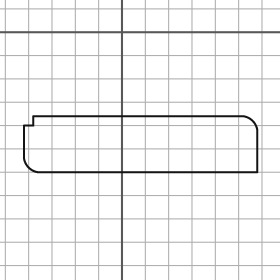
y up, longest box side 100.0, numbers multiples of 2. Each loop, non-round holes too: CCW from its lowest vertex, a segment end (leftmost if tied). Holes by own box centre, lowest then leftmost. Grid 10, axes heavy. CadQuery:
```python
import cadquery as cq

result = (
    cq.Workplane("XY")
    .moveTo(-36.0, -60.0)
    .lineTo(58.0, -60.0)
    .lineTo(58.0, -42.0)
    .threePointArc((56.0, -38.0), (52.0, -36.0))
    .lineTo(-38.0, -36.0)
    .lineTo(-38.0, -40.0)
    .lineTo(-42.0, -40.0)
    .lineTo(-42.0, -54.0)
    .threePointArc((-40.0, -58.0), (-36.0, -60.0))
    .close()
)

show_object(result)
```